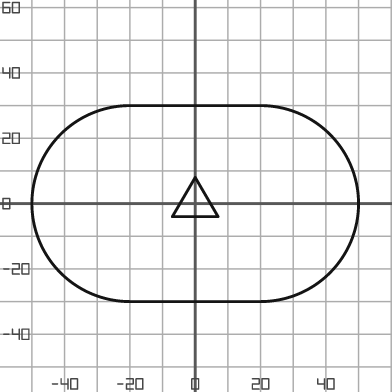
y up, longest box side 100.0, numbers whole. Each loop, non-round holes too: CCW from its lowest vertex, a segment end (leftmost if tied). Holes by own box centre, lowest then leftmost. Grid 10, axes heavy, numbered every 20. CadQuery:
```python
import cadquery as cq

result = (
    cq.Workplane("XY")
    .moveTo(-20.0, -30.0)
    .lineTo(20.0, -30.0)
    .threePointArc((50.0, 0.0), (20.0, 30.0))
    .lineTo(-20.0, 30.0)
    .threePointArc((-50.0, 0.0), (-20.0, -30.0))
    .close()
    .moveTo(-7.0, -4.0)
    .lineTo(7.0, -4.0)
    .lineTo(0.0, 8.0)
    .close()
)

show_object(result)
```